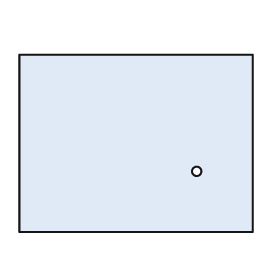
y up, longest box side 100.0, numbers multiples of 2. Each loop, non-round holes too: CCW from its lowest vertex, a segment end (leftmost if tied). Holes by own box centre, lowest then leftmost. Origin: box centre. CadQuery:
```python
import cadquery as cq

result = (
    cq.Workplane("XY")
    .moveTo(-50.0, -38.0)
    .lineTo(50.0, -38.0)
    .lineTo(50.0, 38.0)
    .lineTo(-50.0, 38.0)
    .close()
    .moveTo(26.0, -12.0)
    .circle(2.0)
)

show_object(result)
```